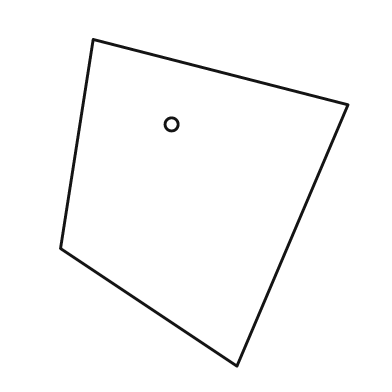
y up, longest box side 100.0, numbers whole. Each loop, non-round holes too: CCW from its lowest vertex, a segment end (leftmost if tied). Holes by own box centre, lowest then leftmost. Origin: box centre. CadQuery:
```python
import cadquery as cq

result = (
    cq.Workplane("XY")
    .moveTo(10.0, -50.0)
    .lineTo(44.0, 30.0)
    .lineTo(-34.0, 50.0)
    .lineTo(-44.0, -14.0)
    .close()
    .moveTo(-10.0, 24.0)
    .circle(2.0)
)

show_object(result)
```